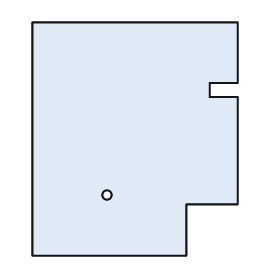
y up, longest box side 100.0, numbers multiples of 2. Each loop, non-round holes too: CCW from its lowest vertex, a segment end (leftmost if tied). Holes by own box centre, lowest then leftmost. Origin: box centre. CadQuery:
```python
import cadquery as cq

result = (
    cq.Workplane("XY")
    .moveTo(-44.0, -50.0)
    .lineTo(22.0, -50.0)
    .lineTo(22.0, -28.0)
    .lineTo(44.0, -28.0)
    .lineTo(44.0, 18.0)
    .lineTo(32.0, 18.0)
    .lineTo(32.0, 24.0)
    .lineTo(44.0, 24.0)
    .lineTo(44.0, 50.0)
    .lineTo(-44.0, 50.0)
    .close()
    .moveTo(-12.0, -24.0)
    .circle(2.0)
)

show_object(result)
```